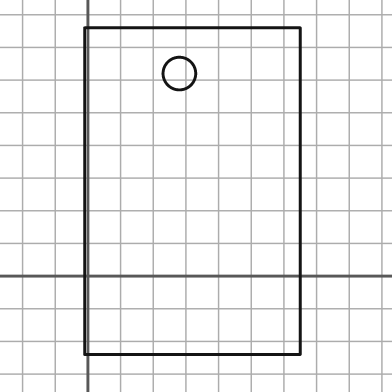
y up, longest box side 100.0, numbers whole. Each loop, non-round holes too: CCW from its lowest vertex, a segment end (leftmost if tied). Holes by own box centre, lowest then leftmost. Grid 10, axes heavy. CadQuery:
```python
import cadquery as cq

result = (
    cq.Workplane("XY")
    .moveTo(-1.0, -24.0)
    .lineTo(65.0, -24.0)
    .lineTo(65.0, 76.0)
    .lineTo(-1.0, 76.0)
    .close()
    .moveTo(28.0, 62.0)
    .circle(5.0)
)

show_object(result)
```